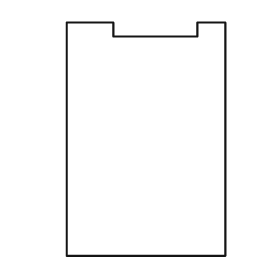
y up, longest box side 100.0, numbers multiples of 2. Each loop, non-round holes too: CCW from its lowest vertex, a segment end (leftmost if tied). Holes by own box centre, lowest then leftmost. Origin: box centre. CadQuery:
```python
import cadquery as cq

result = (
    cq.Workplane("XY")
    .moveTo(-34.0, -50.0)
    .lineTo(34.0, -50.0)
    .lineTo(34.0, 50.0)
    .lineTo(22.0, 50.0)
    .lineTo(22.0, 44.0)
    .lineTo(-14.0, 44.0)
    .lineTo(-14.0, 50.0)
    .lineTo(-34.0, 50.0)
    .close()
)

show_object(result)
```